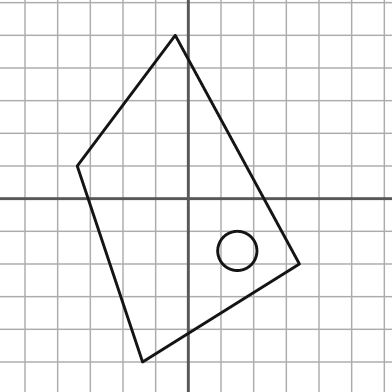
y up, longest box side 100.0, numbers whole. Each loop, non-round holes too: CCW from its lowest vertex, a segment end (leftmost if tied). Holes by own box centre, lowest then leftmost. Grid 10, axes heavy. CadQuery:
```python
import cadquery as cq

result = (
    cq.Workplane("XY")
    .moveTo(-14.0, -50.0)
    .lineTo(34.0, -20.0)
    .lineTo(-4.0, 50.0)
    .lineTo(-34.0, 10.0)
    .close()
    .moveTo(15.0, -16.0)
    .circle(6.0)
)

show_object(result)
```